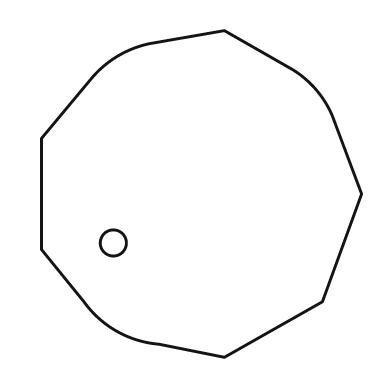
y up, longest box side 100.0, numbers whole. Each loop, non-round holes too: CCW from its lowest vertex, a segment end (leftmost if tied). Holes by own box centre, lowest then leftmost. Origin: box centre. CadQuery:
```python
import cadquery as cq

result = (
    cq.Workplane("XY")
    .moveTo(7.0, -50.0)
    .lineTo(37.0, -33.0)
    .lineTo(49.0, 0.0)
    .lineTo(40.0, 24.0)
    .threePointArc((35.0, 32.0), (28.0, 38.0))
    .lineTo(7.0, 50.0)
    .lineTo(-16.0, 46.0)
    .threePointArc((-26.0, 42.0), (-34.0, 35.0))
    .lineTo(-49.0, 17.0)
    .lineTo(-49.0, -17.0)
    .lineTo(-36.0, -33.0)
    .threePointArc((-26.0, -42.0), (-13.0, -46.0))
    .close()
    .moveTo(-27.0, -15.0)
    .circle(4.0)
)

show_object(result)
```